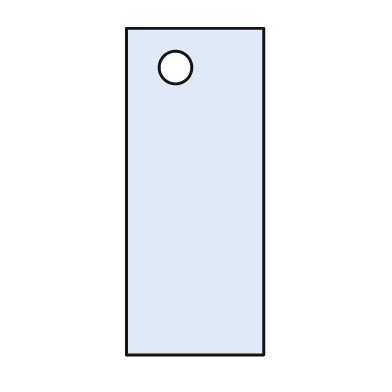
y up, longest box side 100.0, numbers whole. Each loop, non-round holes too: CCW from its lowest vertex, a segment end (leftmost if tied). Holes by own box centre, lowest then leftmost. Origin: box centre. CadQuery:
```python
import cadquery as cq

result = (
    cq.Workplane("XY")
    .moveTo(-21.0, -50.0)
    .lineTo(21.0, -50.0)
    .lineTo(21.0, 50.0)
    .lineTo(-21.0, 50.0)
    .close()
    .moveTo(-6.0, 38.0)
    .circle(5.0)
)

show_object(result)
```